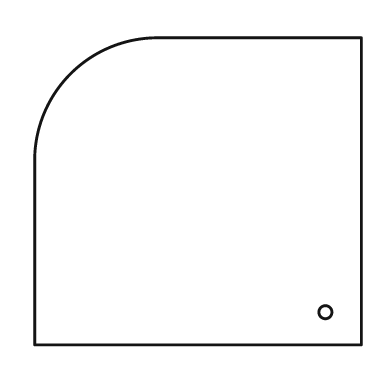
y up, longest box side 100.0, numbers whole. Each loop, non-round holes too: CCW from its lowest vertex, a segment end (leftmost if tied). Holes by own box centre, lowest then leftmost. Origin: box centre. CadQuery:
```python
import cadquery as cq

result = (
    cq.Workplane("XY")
    .moveTo(-50.0, -47.0)
    .lineTo(50.0, -47.0)
    .lineTo(50.0, 47.0)
    .lineTo(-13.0, 47.0)
    .threePointArc((-39.0, 36.0), (-50.0, 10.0))
    .close()
    .moveTo(39.0, -37.0)
    .circle(2.0)
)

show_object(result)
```